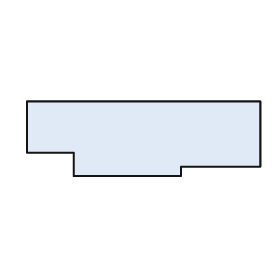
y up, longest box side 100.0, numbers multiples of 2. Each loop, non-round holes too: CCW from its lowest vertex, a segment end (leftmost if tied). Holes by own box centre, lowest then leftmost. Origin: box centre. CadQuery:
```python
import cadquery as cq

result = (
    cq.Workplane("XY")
    .moveTo(-30.0, -16.0)
    .lineTo(16.0, -16.0)
    .lineTo(16.0, -12.0)
    .lineTo(50.0, -12.0)
    .lineTo(50.0, 16.0)
    .lineTo(-50.0, 16.0)
    .lineTo(-50.0, -6.0)
    .lineTo(-30.0, -6.0)
    .close()
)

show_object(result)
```